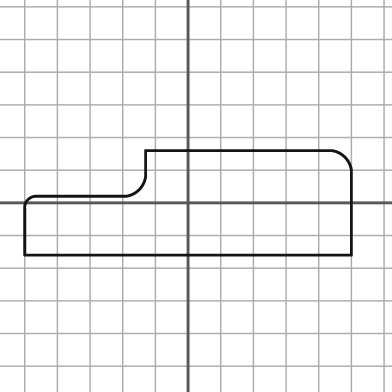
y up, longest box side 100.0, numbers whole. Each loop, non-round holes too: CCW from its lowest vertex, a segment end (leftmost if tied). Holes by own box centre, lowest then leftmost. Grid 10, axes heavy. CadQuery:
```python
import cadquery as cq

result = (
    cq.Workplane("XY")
    .moveTo(-50.0, -16.0)
    .lineTo(50.0, -16.0)
    .lineTo(50.0, 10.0)
    .threePointArc((48.0, 14.0), (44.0, 16.0))
    .lineTo(-13.0, 16.0)
    .lineTo(-13.0, 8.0)
    .threePointArc((-15.0, 4.0), (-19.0, 2.0))
    .lineTo(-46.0, 2.0)
    .threePointArc((-49.0, 1.0), (-50.0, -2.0))
    .close()
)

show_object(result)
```